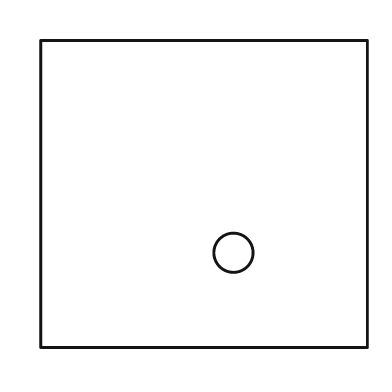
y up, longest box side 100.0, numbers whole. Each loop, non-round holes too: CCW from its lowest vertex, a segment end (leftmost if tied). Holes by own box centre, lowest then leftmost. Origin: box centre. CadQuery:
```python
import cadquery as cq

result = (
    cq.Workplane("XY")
    .moveTo(-50.0, -47.0)
    .lineTo(50.0, -47.0)
    .lineTo(50.0, 47.0)
    .lineTo(-50.0, 47.0)
    .close()
    .moveTo(9.0, -18.0)
    .circle(6.0)
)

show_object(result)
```